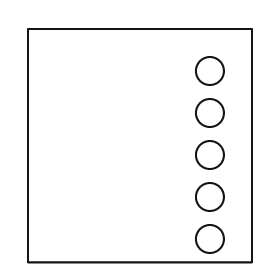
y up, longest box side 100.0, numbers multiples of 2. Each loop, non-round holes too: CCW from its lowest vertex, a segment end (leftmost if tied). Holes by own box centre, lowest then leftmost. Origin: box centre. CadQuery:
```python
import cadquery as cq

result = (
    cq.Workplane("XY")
    .moveTo(-48.0, -50.0)
    .lineTo(48.0, -50.0)
    .lineTo(48.0, 50.0)
    .lineTo(-48.0, 50.0)
    .close()
    .moveTo(30.0, -40.0)
    .circle(6.0)
    .moveTo(30.0, -22.0)
    .circle(6.0)
    .moveTo(30.0, -4.0)
    .circle(6.0)
    .moveTo(30.0, 14.0)
    .circle(6.0)
    .moveTo(30.0, 32.0)
    .circle(6.0)
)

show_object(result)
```